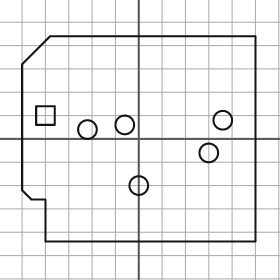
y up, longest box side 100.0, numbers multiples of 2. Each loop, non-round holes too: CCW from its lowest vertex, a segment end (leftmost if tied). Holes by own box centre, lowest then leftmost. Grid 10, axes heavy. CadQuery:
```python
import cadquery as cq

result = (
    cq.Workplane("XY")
    .moveTo(-40.0, -44.0)
    .lineTo(50.0, -44.0)
    .lineTo(50.0, 44.0)
    .lineTo(-38.0, 44.0)
    .lineTo(-50.0, 32.0)
    .lineTo(-50.0, -22.0)
    .lineTo(-46.0, -26.0)
    .lineTo(-40.0, -26.0)
    .close()
    .moveTo(0.0, -20.0)
    .circle(4.0)
    .moveTo(30.0, -6.0)
    .circle(4.0)
    .moveTo(-22.0, 4.0)
    .circle(4.0)
    .moveTo(-6.0, 6.0)
    .circle(4.0)
    .moveTo(36.0, 8.0)
    .circle(4.0)
    .moveTo(-44.0, 6.0)
    .lineTo(-36.0, 6.0)
    .lineTo(-36.0, 14.0)
    .lineTo(-44.0, 14.0)
    .close()
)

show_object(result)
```